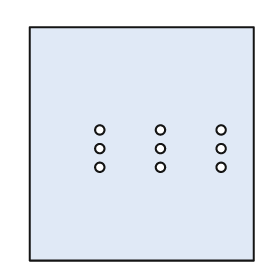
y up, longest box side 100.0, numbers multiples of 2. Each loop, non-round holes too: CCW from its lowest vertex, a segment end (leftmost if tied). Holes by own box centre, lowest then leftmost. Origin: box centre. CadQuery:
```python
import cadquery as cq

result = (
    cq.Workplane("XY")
    .moveTo(-48.0, -50.0)
    .lineTo(48.0, -50.0)
    .lineTo(48.0, 50.0)
    .lineTo(-48.0, 50.0)
    .close()
    .moveTo(-18.0, -10.0)
    .circle(2.0)
    .moveTo(8.0, -10.0)
    .circle(2.0)
    .moveTo(34.0, -10.0)
    .circle(2.0)
    .moveTo(-18.0, -2.0)
    .circle(2.0)
    .moveTo(8.0, -2.0)
    .circle(2.0)
    .moveTo(34.0, -2.0)
    .circle(2.0)
    .moveTo(-18.0, 6.0)
    .circle(2.0)
    .moveTo(8.0, 6.0)
    .circle(2.0)
    .moveTo(34.0, 6.0)
    .circle(2.0)
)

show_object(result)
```